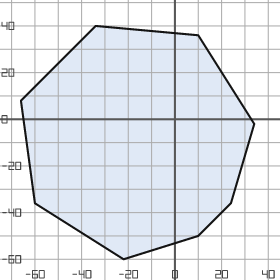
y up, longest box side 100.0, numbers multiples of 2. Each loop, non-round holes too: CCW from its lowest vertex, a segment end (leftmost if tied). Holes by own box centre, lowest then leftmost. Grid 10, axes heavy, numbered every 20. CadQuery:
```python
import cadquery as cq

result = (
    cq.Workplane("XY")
    .moveTo(-22.0, -60.0)
    .lineTo(10.0, -50.0)
    .lineTo(24.0, -36.0)
    .lineTo(34.0, -2.0)
    .lineTo(10.0, 36.0)
    .lineTo(-34.0, 40.0)
    .lineTo(-66.0, 8.0)
    .lineTo(-60.0, -36.0)
    .close()
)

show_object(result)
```